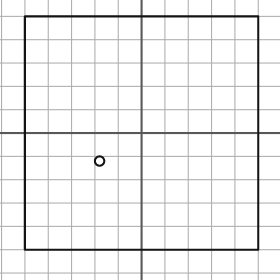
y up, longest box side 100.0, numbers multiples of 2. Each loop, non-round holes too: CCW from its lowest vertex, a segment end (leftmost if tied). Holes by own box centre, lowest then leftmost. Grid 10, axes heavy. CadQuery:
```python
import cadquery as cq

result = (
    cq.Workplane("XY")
    .moveTo(-50.0, -50.0)
    .lineTo(50.0, -50.0)
    .lineTo(50.0, 50.0)
    .lineTo(-50.0, 50.0)
    .close()
    .moveTo(-18.0, -12.0)
    .circle(2.0)
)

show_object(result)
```